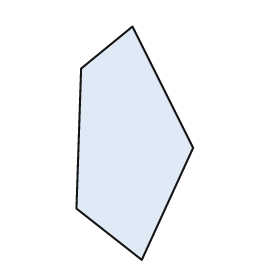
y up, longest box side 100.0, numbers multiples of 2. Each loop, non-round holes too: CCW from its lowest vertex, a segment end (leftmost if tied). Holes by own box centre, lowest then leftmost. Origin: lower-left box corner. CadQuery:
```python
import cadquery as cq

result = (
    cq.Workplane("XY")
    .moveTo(28.0, 0.0)
    .lineTo(50.0, 48.0)
    .lineTo(24.0, 100.0)
    .lineTo(2.0, 82.0)
    .lineTo(0.0, 22.0)
    .close()
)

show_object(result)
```